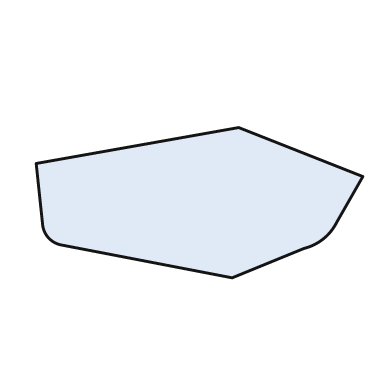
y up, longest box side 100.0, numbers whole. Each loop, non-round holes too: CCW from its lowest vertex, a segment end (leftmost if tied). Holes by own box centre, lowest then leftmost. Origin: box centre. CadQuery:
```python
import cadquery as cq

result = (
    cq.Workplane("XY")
    .moveTo(10.0, -23.0)
    .lineTo(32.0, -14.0)
    .threePointArc((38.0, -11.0), (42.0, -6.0))
    .lineTo(50.0, 8.0)
    .lineTo(12.0, 23.0)
    .lineTo(-50.0, 12.0)
    .lineTo(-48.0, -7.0)
    .threePointArc((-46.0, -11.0), (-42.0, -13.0))
    .close()
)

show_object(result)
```